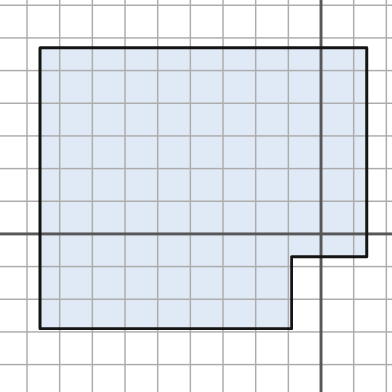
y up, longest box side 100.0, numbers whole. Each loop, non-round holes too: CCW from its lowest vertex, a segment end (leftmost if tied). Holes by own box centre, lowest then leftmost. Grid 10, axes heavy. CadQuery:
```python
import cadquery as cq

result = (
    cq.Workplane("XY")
    .moveTo(-86.0, -29.0)
    .lineTo(-9.0, -29.0)
    .lineTo(-9.0, -7.0)
    .lineTo(14.0, -7.0)
    .lineTo(14.0, 57.0)
    .lineTo(-86.0, 57.0)
    .close()
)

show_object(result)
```